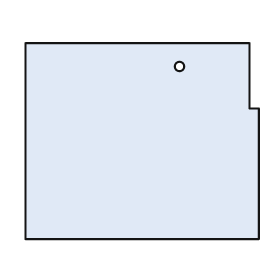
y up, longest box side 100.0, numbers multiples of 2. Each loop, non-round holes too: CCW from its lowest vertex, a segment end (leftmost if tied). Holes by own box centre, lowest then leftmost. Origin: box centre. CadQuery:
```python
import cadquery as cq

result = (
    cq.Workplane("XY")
    .moveTo(-50.0, -42.0)
    .lineTo(50.0, -42.0)
    .lineTo(50.0, 14.0)
    .lineTo(46.0, 14.0)
    .lineTo(46.0, 42.0)
    .lineTo(-50.0, 42.0)
    .close()
    .moveTo(16.0, 32.0)
    .circle(2.0)
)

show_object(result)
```